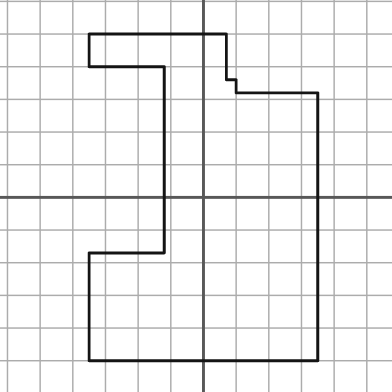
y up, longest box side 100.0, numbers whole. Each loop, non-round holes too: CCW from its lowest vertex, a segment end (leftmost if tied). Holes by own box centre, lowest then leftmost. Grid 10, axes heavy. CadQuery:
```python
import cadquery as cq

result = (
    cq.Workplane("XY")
    .moveTo(-35.0, -50.0)
    .lineTo(35.0, -50.0)
    .lineTo(35.0, 32.0)
    .lineTo(10.0, 32.0)
    .lineTo(10.0, 36.0)
    .lineTo(7.0, 36.0)
    .lineTo(7.0, 50.0)
    .lineTo(-35.0, 50.0)
    .lineTo(-35.0, 40.0)
    .lineTo(-12.0, 40.0)
    .lineTo(-12.0, -17.0)
    .lineTo(-35.0, -17.0)
    .close()
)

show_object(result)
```